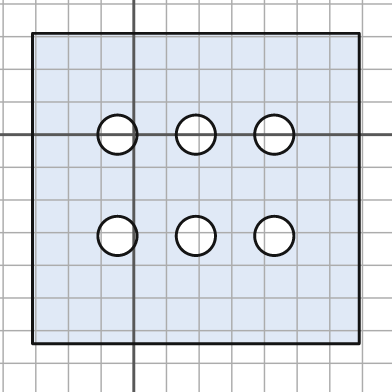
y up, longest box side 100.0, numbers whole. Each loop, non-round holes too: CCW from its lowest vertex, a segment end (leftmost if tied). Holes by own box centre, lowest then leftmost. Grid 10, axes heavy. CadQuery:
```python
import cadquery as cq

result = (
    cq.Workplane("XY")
    .moveTo(-31.0, -64.0)
    .lineTo(69.0, -64.0)
    .lineTo(69.0, 31.0)
    .lineTo(-31.0, 31.0)
    .close()
    .moveTo(-5.0, -31.0)
    .circle(6.0)
    .moveTo(19.0, -31.0)
    .circle(6.0)
    .moveTo(43.0, -31.0)
    .circle(6.0)
    .moveTo(-5.0, 0.0)
    .circle(6.0)
    .moveTo(19.0, 0.0)
    .circle(6.0)
    .moveTo(43.0, 0.0)
    .circle(6.0)
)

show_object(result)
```